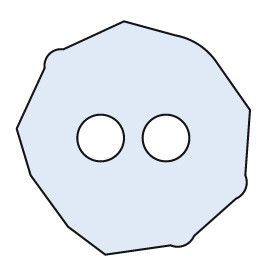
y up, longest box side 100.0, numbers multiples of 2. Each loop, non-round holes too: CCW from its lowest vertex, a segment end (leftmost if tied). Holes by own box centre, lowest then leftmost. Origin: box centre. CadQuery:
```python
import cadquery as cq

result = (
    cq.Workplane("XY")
    .moveTo(-12.0, -50.0)
    .lineTo(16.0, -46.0)
    .threePointArc((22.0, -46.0), (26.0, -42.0))
    .lineTo(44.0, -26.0)
    .threePointArc((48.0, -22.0), (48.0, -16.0))
    .lineTo(50.0, 12.0)
    .lineTo(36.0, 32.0)
    .threePointArc((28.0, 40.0), (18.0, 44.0))
    .lineTo(-4.0, 50.0)
    .lineTo(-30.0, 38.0)
    .threePointArc((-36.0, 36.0), (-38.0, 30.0))
    .lineTo(-50.0, 4.0)
    .lineTo(-44.0, -16.0)
    .lineTo(-28.0, -38.0)
    .close()
    .moveTo(-14.0, 0.0)
    .circle(10.0)
    .moveTo(14.0, 0.0)
    .circle(10.0)
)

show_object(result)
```